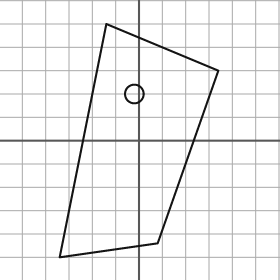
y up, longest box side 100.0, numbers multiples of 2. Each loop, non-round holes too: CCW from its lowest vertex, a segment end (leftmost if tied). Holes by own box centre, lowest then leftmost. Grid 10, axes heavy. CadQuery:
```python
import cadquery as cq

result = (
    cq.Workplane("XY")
    .moveTo(-34.0, -50.0)
    .lineTo(8.0, -44.0)
    .lineTo(34.0, 30.0)
    .lineTo(-14.0, 50.0)
    .close()
    .moveTo(-2.0, 20.0)
    .circle(4.0)
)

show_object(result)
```